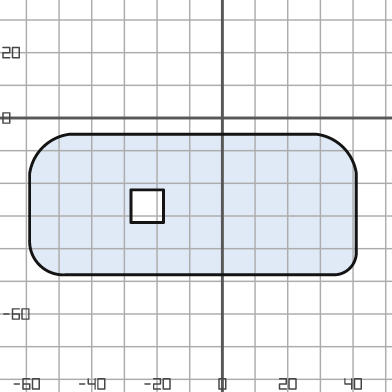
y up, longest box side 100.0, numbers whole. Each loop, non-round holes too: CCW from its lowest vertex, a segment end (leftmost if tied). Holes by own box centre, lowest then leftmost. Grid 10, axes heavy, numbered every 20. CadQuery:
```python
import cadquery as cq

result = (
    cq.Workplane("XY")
    .moveTo(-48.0, -48.0)
    .lineTo(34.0, -48.0)
    .threePointArc((39.0, -46.0), (41.0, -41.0))
    .lineTo(41.0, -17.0)
    .threePointArc((37.0, -9.0), (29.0, -5.0))
    .lineTo(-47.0, -5.0)
    .threePointArc((-55.0, -9.0), (-59.0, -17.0))
    .lineTo(-59.0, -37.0)
    .threePointArc((-56.0, -45.0), (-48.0, -48.0))
    .close()
    .moveTo(-28.0, -32.0)
    .lineTo(-18.0, -32.0)
    .lineTo(-18.0, -22.0)
    .lineTo(-28.0, -22.0)
    .close()
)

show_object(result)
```